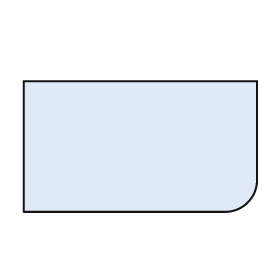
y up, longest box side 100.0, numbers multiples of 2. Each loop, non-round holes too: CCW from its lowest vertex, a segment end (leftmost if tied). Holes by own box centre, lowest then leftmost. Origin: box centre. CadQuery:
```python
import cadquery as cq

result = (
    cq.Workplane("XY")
    .moveTo(-50.0, -28.0)
    .lineTo(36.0, -28.0)
    .threePointArc((46.0, -24.0), (50.0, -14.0))
    .lineTo(50.0, 28.0)
    .lineTo(-50.0, 28.0)
    .close()
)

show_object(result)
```